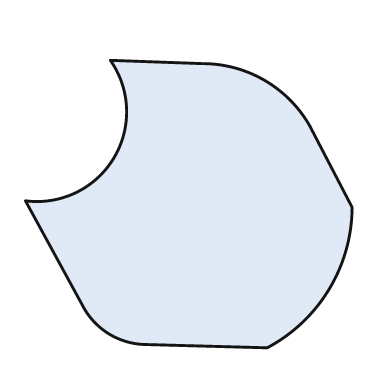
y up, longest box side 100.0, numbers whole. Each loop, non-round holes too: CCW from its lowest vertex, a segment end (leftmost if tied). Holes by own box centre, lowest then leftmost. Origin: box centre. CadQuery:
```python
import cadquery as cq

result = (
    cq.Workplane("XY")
    .moveTo(24.0, -44.0)
    .threePointArc((43.0, -26.0), (50.0, -1.0))
    .lineTo(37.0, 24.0)
    .threePointArc((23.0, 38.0), (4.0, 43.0))
    .lineTo(-24.0, 44.0)
    .threePointArc((-23.0, 14.0), (-50.0, 1.0))
    .lineTo(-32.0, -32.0)
    .threePointArc((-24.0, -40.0), (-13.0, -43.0))
    .close()
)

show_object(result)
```